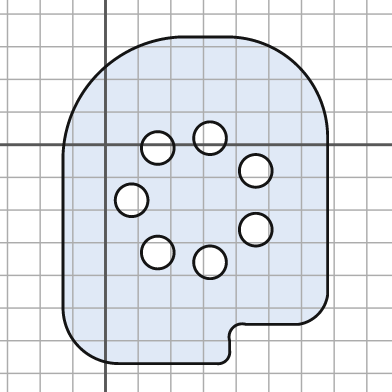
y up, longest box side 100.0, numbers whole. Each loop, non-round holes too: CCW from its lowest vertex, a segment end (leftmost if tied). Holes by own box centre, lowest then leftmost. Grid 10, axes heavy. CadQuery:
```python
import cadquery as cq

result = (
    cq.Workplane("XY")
    .moveTo(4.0, -67.0)
    .lineTo(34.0, -67.0)
    .threePointArc((37.0, -66.0), (38.0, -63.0))
    .lineTo(38.0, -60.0)
    .threePointArc((39.0, -56.0), (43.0, -55.0))
    .lineTo(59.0, -55.0)
    .threePointArc((65.0, -52.0), (68.0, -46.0))
    .lineTo(68.0, 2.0)
    .threePointArc((59.0, 24.0), (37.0, 33.0))
    .lineTo(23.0, 33.0)
    .threePointArc((-2.0, 22.0), (-13.0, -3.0))
    .lineTo(-13.0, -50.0)
    .threePointArc((-8.0, -62.0), (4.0, -67.0))
    .close()
    .moveTo(32.0, -36.0)
    .circle(5.0)
    .moveTo(16.0, -33.0)
    .circle(5.0)
    .moveTo(46.0, -26.0)
    .circle(5.0)
    .moveTo(8.0, -17.0)
    .circle(5.0)
    .moveTo(46.0, -8.0)
    .circle(5.0)
    .moveTo(16.0, -1.0)
    .circle(5.0)
    .moveTo(32.0, 2.0)
    .circle(5.0)
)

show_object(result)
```